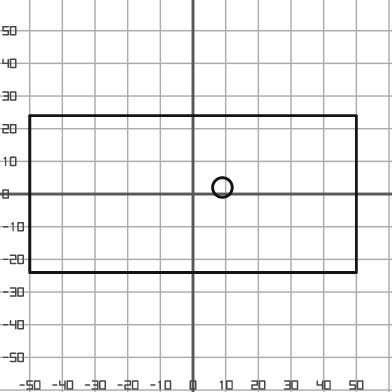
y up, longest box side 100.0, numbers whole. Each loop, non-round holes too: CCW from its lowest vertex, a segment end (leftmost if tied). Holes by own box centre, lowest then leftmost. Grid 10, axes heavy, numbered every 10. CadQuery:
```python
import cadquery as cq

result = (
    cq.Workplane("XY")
    .moveTo(-50.0, -24.0)
    .lineTo(50.0, -24.0)
    .lineTo(50.0, 24.0)
    .lineTo(-50.0, 24.0)
    .close()
    .moveTo(9.0, 2.0)
    .circle(3.0)
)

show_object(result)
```